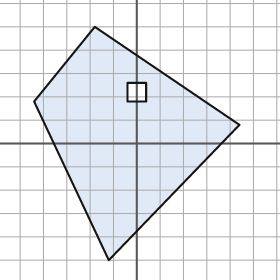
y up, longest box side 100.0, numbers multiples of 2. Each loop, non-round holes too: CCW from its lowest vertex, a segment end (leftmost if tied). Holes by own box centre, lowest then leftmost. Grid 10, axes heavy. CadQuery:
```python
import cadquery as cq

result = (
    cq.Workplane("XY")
    .moveTo(-12.0, -50.0)
    .lineTo(44.0, 8.0)
    .lineTo(-18.0, 50.0)
    .lineTo(-44.0, 18.0)
    .close()
    .moveTo(-4.0, 18.0)
    .lineTo(4.0, 18.0)
    .lineTo(4.0, 26.0)
    .lineTo(-4.0, 26.0)
    .close()
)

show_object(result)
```